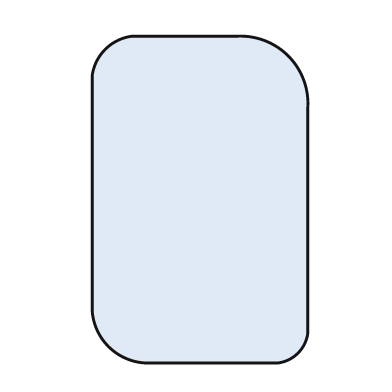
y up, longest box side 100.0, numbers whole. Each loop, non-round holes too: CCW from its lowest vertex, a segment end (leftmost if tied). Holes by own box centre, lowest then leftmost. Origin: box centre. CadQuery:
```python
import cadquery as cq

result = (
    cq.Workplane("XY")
    .moveTo(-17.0, -50.0)
    .lineTo(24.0, -50.0)
    .threePointArc((30.0, -47.0), (33.0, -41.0))
    .lineTo(33.0, 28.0)
    .threePointArc((27.0, 44.0), (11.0, 50.0))
    .lineTo(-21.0, 50.0)
    .threePointArc((-29.0, 46.0), (-33.0, 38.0))
    .lineTo(-33.0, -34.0)
    .threePointArc((-28.0, -45.0), (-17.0, -50.0))
    .close()
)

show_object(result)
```